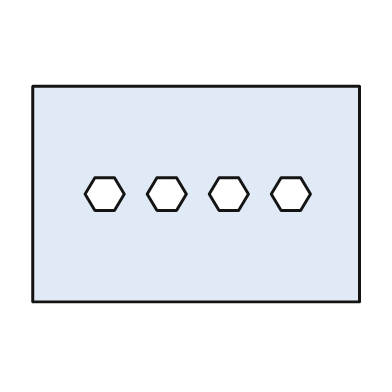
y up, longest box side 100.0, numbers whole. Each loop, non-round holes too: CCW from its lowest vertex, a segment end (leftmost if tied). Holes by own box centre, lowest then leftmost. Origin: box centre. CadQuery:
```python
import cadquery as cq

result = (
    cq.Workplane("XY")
    .moveTo(-50.0, -33.0)
    .lineTo(50.0, -33.0)
    .lineTo(50.0, 33.0)
    .lineTo(-50.0, 33.0)
    .close()
    .moveTo(-31.0, -5.0)
    .lineTo(-25.0, -5.0)
    .lineTo(-22.0, 0.0)
    .lineTo(-25.0, 5.0)
    .lineTo(-31.0, 5.0)
    .lineTo(-34.0, 0.0)
    .close()
    .moveTo(-12.0, -5.0)
    .lineTo(-6.0, -5.0)
    .lineTo(-3.0, 0.0)
    .lineTo(-6.0, 5.0)
    .lineTo(-12.0, 5.0)
    .lineTo(-15.0, 0.0)
    .close()
    .moveTo(7.0, -5.0)
    .lineTo(13.0, -5.0)
    .lineTo(16.0, 0.0)
    .lineTo(13.0, 5.0)
    .lineTo(7.0, 5.0)
    .lineTo(4.0, 0.0)
    .close()
    .moveTo(26.0, -5.0)
    .lineTo(32.0, -5.0)
    .lineTo(35.0, 0.0)
    .lineTo(32.0, 5.0)
    .lineTo(26.0, 5.0)
    .lineTo(23.0, 0.0)
    .close()
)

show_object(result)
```